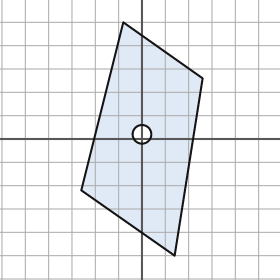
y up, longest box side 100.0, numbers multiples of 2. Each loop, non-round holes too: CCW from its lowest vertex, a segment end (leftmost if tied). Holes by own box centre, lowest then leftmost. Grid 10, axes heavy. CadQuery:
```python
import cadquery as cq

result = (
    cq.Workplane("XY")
    .moveTo(14.0, -50.0)
    .lineTo(26.0, 26.0)
    .lineTo(-8.0, 50.0)
    .lineTo(-26.0, -22.0)
    .close()
    .moveTo(0.0, 2.0)
    .circle(4.0)
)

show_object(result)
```